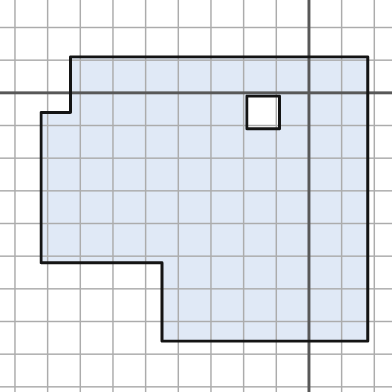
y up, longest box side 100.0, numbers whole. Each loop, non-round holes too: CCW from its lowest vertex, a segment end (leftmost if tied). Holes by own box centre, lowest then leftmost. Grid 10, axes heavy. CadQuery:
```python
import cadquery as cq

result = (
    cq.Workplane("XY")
    .moveTo(-45.0, -76.0)
    .lineTo(18.0, -76.0)
    .lineTo(18.0, 11.0)
    .lineTo(-73.0, 11.0)
    .lineTo(-73.0, -6.0)
    .lineTo(-82.0, -6.0)
    .lineTo(-82.0, -52.0)
    .lineTo(-45.0, -52.0)
    .close()
    .moveTo(-19.0, -11.0)
    .lineTo(-9.0, -11.0)
    .lineTo(-9.0, -1.0)
    .lineTo(-19.0, -1.0)
    .close()
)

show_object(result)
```